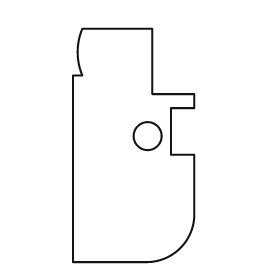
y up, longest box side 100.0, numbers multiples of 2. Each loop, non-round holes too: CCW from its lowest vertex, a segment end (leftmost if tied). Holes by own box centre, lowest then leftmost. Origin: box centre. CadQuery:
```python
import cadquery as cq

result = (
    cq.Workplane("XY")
    .moveTo(-26.0, -50.0)
    .lineTo(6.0, -50.0)
    .threePointArc((20.0, -44.0), (26.0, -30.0))
    .lineTo(26.0, -4.0)
    .lineTo(16.0, -4.0)
    .lineTo(16.0, 16.0)
    .lineTo(26.0, 16.0)
    .lineTo(26.0, 22.0)
    .lineTo(8.0, 22.0)
    .lineTo(8.0, 50.0)
    .lineTo(-22.0, 50.0)
    .threePointArc((-24.0, 40.0), (-22.0, 30.0))
    .lineTo(-26.0, 30.0)
    .close()
    .moveTo(6.0, 4.0)
    .circle(6.0)
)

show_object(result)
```